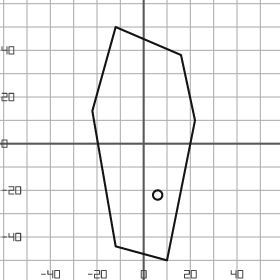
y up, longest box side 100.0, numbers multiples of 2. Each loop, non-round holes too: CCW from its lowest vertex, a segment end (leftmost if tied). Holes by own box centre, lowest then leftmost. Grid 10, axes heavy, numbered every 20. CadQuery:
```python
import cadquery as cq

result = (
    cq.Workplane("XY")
    .moveTo(10.0, -50.0)
    .lineTo(22.0, 10.0)
    .lineTo(16.0, 38.0)
    .lineTo(-12.0, 50.0)
    .lineTo(-22.0, 14.0)
    .lineTo(-12.0, -44.0)
    .close()
    .moveTo(6.0, -22.0)
    .circle(2.0)
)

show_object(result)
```